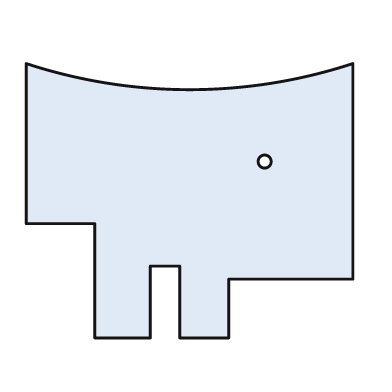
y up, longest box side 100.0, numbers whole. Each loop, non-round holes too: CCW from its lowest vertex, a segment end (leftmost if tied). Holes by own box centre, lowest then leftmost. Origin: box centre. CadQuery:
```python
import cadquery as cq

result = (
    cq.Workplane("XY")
    .moveTo(-29.0, -42.0)
    .lineTo(-12.0, -42.0)
    .lineTo(-12.0, -20.0)
    .lineTo(-3.0, -20.0)
    .lineTo(-3.0, -42.0)
    .lineTo(12.0, -42.0)
    .lineTo(12.0, -24.0)
    .lineTo(50.0, -24.0)
    .lineTo(50.0, 42.0)
    .threePointArc((0.0, 34.0), (-50.0, 42.0))
    .lineTo(-50.0, -7.0)
    .lineTo(-29.0, -7.0)
    .close()
    .moveTo(23.0, 12.0)
    .circle(2.0)
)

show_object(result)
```